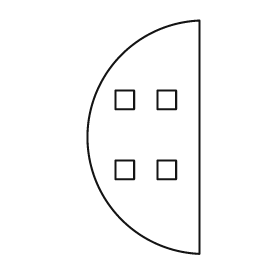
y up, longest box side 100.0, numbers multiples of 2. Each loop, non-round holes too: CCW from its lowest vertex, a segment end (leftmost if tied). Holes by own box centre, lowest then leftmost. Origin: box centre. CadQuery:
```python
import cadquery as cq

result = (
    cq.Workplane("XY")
    .moveTo(24.0, -50.0)
    .lineTo(24.0, 50.0)
    .threePointArc((-24.0, 0.0), (24.0, -50.0))
    .close()
    .moveTo(-12.0, -18.0)
    .lineTo(-4.0, -18.0)
    .lineTo(-4.0, -10.0)
    .lineTo(-12.0, -10.0)
    .close()
    .moveTo(6.0, -18.0)
    .lineTo(14.0, -18.0)
    .lineTo(14.0, -10.0)
    .lineTo(6.0, -10.0)
    .close()
    .moveTo(-12.0, 12.0)
    .lineTo(-4.0, 12.0)
    .lineTo(-4.0, 20.0)
    .lineTo(-12.0, 20.0)
    .close()
    .moveTo(6.0, 12.0)
    .lineTo(14.0, 12.0)
    .lineTo(14.0, 20.0)
    .lineTo(6.0, 20.0)
    .close()
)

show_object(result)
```